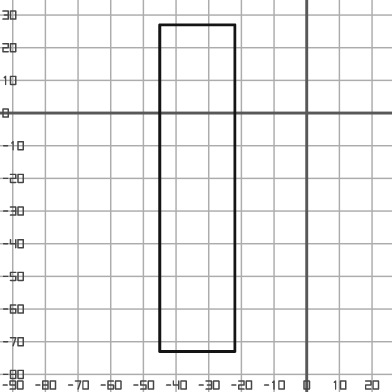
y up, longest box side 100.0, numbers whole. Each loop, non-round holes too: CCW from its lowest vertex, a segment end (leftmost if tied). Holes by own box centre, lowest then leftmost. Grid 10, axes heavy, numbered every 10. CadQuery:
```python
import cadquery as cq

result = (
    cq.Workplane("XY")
    .moveTo(-45.0, -73.0)
    .lineTo(-22.0, -73.0)
    .lineTo(-22.0, 27.0)
    .lineTo(-45.0, 27.0)
    .close()
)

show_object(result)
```